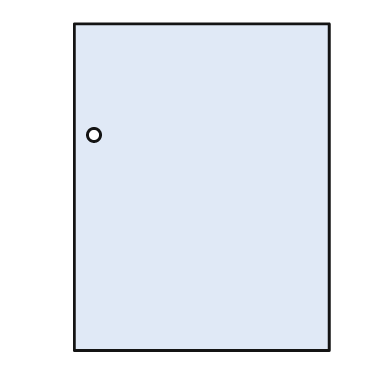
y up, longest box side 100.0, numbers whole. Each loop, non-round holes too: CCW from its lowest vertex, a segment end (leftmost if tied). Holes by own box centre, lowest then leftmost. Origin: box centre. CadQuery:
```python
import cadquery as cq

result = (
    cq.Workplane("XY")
    .moveTo(-39.0, -50.0)
    .lineTo(39.0, -50.0)
    .lineTo(39.0, 50.0)
    .lineTo(-39.0, 50.0)
    .close()
    .moveTo(-33.0, 16.0)
    .circle(2.0)
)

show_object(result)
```